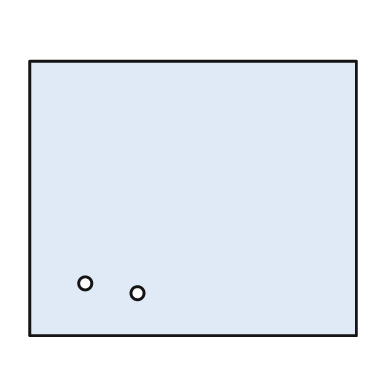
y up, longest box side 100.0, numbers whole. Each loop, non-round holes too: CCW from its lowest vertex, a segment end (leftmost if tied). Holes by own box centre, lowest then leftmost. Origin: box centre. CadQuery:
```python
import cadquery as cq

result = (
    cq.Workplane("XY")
    .moveTo(-50.0, -42.0)
    .lineTo(50.0, -42.0)
    .lineTo(50.0, 42.0)
    .lineTo(-50.0, 42.0)
    .close()
    .moveTo(-17.0, -29.0)
    .circle(2.0)
    .moveTo(-33.0, -26.0)
    .circle(2.0)
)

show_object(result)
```